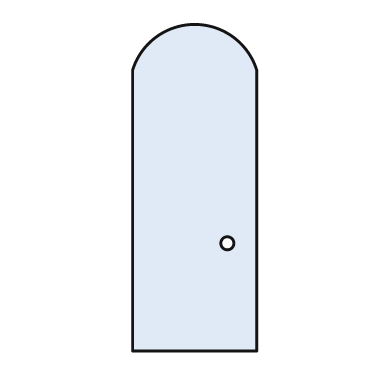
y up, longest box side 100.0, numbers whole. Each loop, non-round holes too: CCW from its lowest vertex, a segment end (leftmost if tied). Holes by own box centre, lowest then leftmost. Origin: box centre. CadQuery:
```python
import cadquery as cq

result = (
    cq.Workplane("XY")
    .moveTo(-19.0, -50.0)
    .lineTo(19.0, -50.0)
    .lineTo(19.0, 36.0)
    .threePointArc((0.0, 50.0), (-19.0, 36.0))
    .close()
    .moveTo(10.0, -17.0)
    .circle(2.0)
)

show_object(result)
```